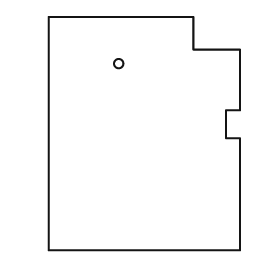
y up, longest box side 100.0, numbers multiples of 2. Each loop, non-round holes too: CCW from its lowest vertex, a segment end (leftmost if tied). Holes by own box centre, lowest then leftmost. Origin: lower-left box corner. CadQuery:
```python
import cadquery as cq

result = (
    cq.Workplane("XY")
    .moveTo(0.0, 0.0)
    .lineTo(82.0, 0.0)
    .lineTo(82.0, 48.0)
    .lineTo(76.0, 48.0)
    .lineTo(76.0, 60.0)
    .lineTo(82.0, 60.0)
    .lineTo(82.0, 86.0)
    .lineTo(62.0, 86.0)
    .lineTo(62.0, 100.0)
    .lineTo(0.0, 100.0)
    .close()
    .moveTo(30.0, 80.0)
    .circle(2.0)
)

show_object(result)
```